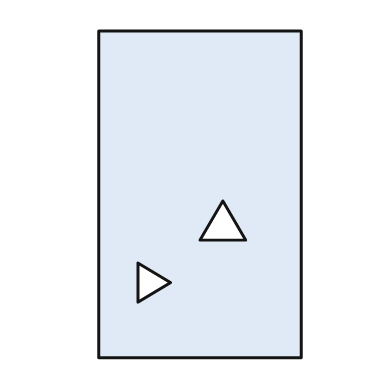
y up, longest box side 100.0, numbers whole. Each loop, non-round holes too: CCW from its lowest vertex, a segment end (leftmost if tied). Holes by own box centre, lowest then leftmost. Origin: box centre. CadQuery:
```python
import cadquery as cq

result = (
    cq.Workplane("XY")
    .moveTo(-31.0, -50.0)
    .lineTo(31.0, -50.0)
    .lineTo(31.0, 50.0)
    .lineTo(-31.0, 50.0)
    .close()
    .moveTo(-19.0, -33.0)
    .lineTo(-9.0, -27.0)
    .lineTo(-19.0, -21.0)
    .close()
    .moveTo(0.0, -14.0)
    .lineTo(14.0, -14.0)
    .lineTo(7.0, -2.0)
    .close()
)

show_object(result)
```